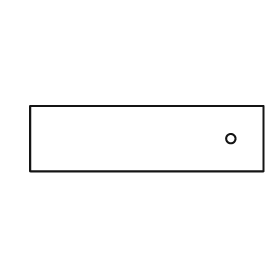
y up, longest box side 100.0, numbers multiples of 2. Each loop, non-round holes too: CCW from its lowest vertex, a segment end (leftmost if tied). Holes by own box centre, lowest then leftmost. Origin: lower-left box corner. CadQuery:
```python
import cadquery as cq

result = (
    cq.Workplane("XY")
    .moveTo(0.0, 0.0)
    .lineTo(100.0, 0.0)
    .lineTo(100.0, 28.0)
    .lineTo(0.0, 28.0)
    .close()
    .moveTo(86.0, 14.0)
    .circle(2.0)
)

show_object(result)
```